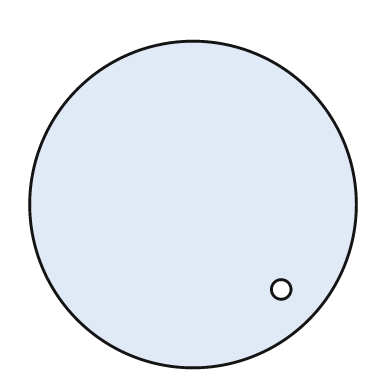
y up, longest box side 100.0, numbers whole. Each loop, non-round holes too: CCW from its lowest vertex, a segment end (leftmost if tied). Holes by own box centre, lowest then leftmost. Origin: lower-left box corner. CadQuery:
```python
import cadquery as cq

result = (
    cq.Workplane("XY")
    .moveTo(50.0, 50.0)
    .circle(50.0)
    .moveTo(77.0, 24.0)
    .circle(3.0)
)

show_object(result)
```